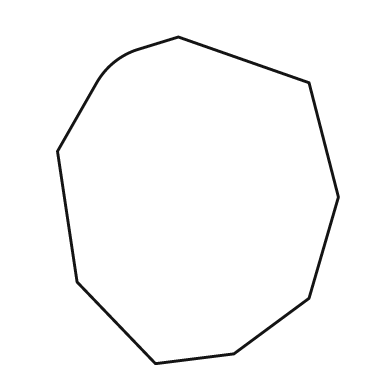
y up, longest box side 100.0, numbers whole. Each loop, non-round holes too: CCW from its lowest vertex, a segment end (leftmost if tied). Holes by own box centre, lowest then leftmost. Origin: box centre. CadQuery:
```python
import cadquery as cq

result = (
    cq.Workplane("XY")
    .moveTo(-13.0, -50.0)
    .lineTo(11.0, -47.0)
    .lineTo(34.0, -30.0)
    .lineTo(43.0, 1.0)
    .lineTo(34.0, 36.0)
    .lineTo(-6.0, 50.0)
    .lineTo(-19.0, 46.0)
    .threePointArc((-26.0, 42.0), (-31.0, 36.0))
    .lineTo(-43.0, 15.0)
    .lineTo(-37.0, -25.0)
    .close()
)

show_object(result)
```